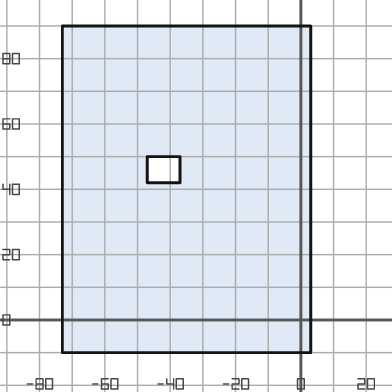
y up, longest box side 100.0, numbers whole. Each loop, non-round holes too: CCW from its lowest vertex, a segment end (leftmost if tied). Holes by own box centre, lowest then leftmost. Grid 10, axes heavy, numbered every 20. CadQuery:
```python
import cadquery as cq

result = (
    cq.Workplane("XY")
    .moveTo(-73.0, -10.0)
    .lineTo(3.0, -10.0)
    .lineTo(3.0, 90.0)
    .lineTo(-73.0, 90.0)
    .close()
    .moveTo(-47.0, 42.0)
    .lineTo(-37.0, 42.0)
    .lineTo(-37.0, 50.0)
    .lineTo(-47.0, 50.0)
    .close()
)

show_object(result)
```